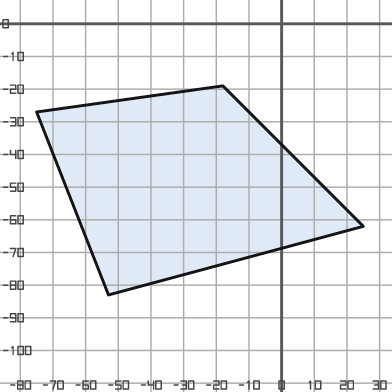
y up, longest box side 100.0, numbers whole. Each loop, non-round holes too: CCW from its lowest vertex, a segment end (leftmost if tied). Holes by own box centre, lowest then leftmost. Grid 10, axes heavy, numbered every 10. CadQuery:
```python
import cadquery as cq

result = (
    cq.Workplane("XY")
    .moveTo(-53.0, -83.0)
    .lineTo(25.0, -62.0)
    .lineTo(-18.0, -19.0)
    .lineTo(-75.0, -27.0)
    .close()
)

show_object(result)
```